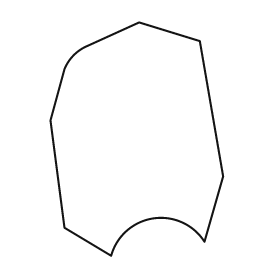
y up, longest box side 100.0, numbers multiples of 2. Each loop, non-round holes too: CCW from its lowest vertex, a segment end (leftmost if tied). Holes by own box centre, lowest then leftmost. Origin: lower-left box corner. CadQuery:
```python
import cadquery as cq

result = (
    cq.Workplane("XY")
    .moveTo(26.0, 0.0)
    .threePointArc((44.0, 16.0), (66.0, 6.0))
    .lineTo(74.0, 34.0)
    .lineTo(64.0, 92.0)
    .lineTo(38.0, 100.0)
    .lineTo(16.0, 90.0)
    .threePointArc((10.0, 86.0), (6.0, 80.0))
    .lineTo(0.0, 58.0)
    .lineTo(6.0, 12.0)
    .close()
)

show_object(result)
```